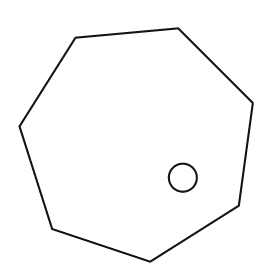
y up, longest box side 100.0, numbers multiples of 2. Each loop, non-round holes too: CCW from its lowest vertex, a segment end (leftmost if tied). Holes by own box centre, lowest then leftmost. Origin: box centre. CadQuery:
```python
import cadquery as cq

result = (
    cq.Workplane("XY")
    .moveTo(6.0, -50.0)
    .lineTo(44.0, -26.0)
    .lineTo(50.0, 18.0)
    .lineTo(18.0, 50.0)
    .lineTo(-26.0, 46.0)
    .lineTo(-50.0, 8.0)
    .lineTo(-36.0, -36.0)
    .close()
    .moveTo(20.0, -14.0)
    .circle(6.0)
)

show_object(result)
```